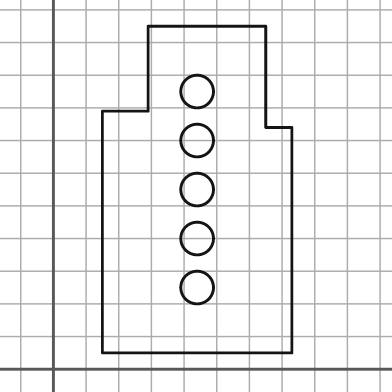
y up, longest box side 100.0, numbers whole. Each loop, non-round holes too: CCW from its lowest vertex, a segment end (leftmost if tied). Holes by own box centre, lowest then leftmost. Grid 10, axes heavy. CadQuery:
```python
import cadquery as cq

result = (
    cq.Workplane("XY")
    .moveTo(15.0, 5.0)
    .lineTo(73.0, 5.0)
    .lineTo(73.0, 74.0)
    .lineTo(65.0, 74.0)
    .lineTo(65.0, 105.0)
    .lineTo(29.0, 105.0)
    .lineTo(29.0, 79.0)
    .lineTo(15.0, 79.0)
    .close()
    .moveTo(44.0, 25.0)
    .circle(5.0)
    .moveTo(44.0, 40.0)
    .circle(5.0)
    .moveTo(44.0, 55.0)
    .circle(5.0)
    .moveTo(44.0, 70.0)
    .circle(5.0)
    .moveTo(44.0, 85.0)
    .circle(5.0)
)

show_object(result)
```